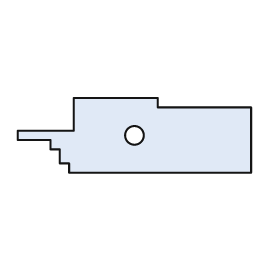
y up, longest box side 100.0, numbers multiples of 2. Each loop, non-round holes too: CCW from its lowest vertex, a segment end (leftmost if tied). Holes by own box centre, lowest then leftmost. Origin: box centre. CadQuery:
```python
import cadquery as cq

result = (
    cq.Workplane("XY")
    .moveTo(-28.0, -16.0)
    .lineTo(50.0, -16.0)
    .lineTo(50.0, 12.0)
    .lineTo(10.0, 12.0)
    .lineTo(10.0, 16.0)
    .lineTo(-26.0, 16.0)
    .lineTo(-26.0, 2.0)
    .lineTo(-50.0, 2.0)
    .lineTo(-50.0, -2.0)
    .lineTo(-36.0, -2.0)
    .lineTo(-36.0, -6.0)
    .lineTo(-32.0, -6.0)
    .lineTo(-32.0, -12.0)
    .lineTo(-28.0, -12.0)
    .close()
    .moveTo(0.0, 0.0)
    .circle(4.0)
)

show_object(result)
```